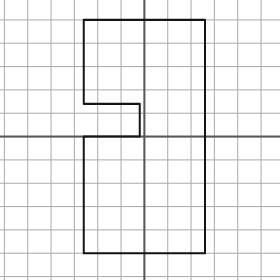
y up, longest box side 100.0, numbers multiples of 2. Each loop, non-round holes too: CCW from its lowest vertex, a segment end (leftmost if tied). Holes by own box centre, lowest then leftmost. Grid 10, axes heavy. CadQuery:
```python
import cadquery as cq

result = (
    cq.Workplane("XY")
    .moveTo(-26.0, -50.0)
    .lineTo(26.0, -50.0)
    .lineTo(26.0, 50.0)
    .lineTo(-26.0, 50.0)
    .lineTo(-26.0, 14.0)
    .lineTo(-2.0, 14.0)
    .lineTo(-2.0, 0.0)
    .lineTo(-26.0, 0.0)
    .close()
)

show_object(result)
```